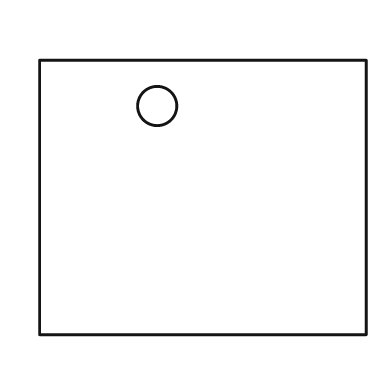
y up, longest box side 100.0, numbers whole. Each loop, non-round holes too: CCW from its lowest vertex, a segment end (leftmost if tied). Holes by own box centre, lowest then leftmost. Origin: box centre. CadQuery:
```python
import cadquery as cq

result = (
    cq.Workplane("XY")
    .moveTo(-50.0, -42.0)
    .lineTo(50.0, -42.0)
    .lineTo(50.0, 42.0)
    .lineTo(-50.0, 42.0)
    .close()
    .moveTo(-14.0, 28.0)
    .circle(6.0)
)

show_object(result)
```